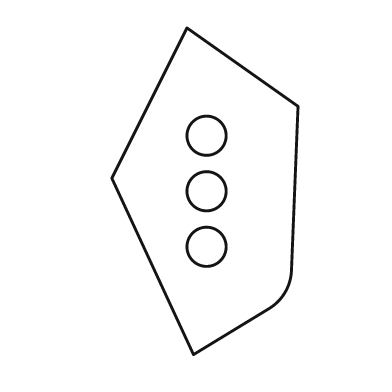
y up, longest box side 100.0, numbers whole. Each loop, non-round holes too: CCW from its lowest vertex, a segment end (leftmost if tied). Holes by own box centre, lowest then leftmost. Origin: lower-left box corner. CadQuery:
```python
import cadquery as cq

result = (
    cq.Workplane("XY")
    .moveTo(25.0, 0.0)
    .lineTo(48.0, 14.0)
    .threePointArc((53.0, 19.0), (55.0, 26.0))
    .lineTo(57.0, 76.0)
    .lineTo(23.0, 100.0)
    .lineTo(0.0, 54.0)
    .close()
    .moveTo(29.0, 33.0)
    .circle(6.0)
    .moveTo(29.0, 50.0)
    .circle(6.0)
    .moveTo(29.0, 67.0)
    .circle(6.0)
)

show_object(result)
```